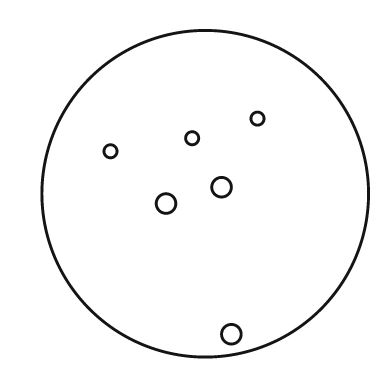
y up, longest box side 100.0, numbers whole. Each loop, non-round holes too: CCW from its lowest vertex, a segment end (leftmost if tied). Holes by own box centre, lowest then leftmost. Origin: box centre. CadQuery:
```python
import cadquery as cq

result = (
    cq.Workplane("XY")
    .moveTo(0.0, 0.0)
    .circle(50.0)
    .moveTo(8.0, -43.0)
    .circle(3.0)
    .moveTo(-12.0, -3.0)
    .circle(3.0)
    .moveTo(5.0, 2.0)
    .circle(3.0)
    .moveTo(-29.0, 13.0)
    .circle(2.0)
    .moveTo(-4.0, 17.0)
    .circle(2.0)
    .moveTo(16.0, 23.0)
    .circle(2.0)
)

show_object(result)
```